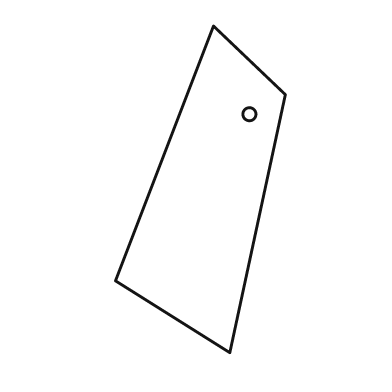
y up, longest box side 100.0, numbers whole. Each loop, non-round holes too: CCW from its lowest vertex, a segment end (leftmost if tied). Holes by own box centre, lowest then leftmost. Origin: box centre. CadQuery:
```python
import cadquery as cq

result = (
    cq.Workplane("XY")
    .moveTo(9.0, -50.0)
    .lineTo(26.0, 29.0)
    .lineTo(4.0, 50.0)
    .lineTo(-26.0, -28.0)
    .close()
    .moveTo(15.0, 23.0)
    .circle(2.0)
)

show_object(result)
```